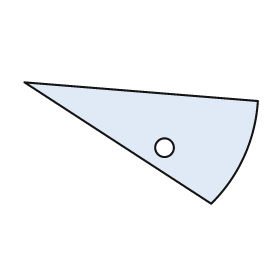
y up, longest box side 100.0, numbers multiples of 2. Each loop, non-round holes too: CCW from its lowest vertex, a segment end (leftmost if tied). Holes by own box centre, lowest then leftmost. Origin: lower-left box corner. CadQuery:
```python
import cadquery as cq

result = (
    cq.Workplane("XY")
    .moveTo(80.0, 0.0)
    .threePointArc((94.0, 20.0), (100.0, 44.0))
    .lineTo(0.0, 52.0)
    .close()
    .moveTo(60.0, 24.0)
    .circle(4.0)
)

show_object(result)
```